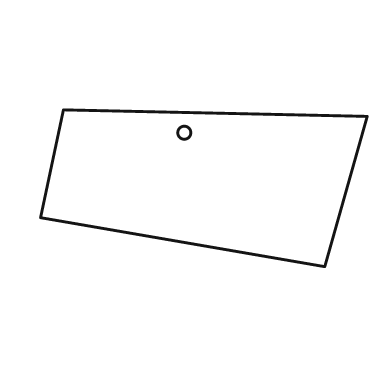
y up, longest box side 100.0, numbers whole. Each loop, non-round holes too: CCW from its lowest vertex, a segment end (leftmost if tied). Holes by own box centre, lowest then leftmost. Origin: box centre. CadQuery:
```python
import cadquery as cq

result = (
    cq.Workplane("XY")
    .moveTo(37.0, -24.0)
    .lineTo(50.0, 22.0)
    .lineTo(-43.0, 24.0)
    .lineTo(-50.0, -9.0)
    .close()
    .moveTo(-6.0, 17.0)
    .circle(2.0)
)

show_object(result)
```